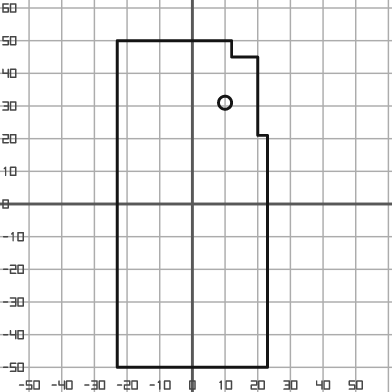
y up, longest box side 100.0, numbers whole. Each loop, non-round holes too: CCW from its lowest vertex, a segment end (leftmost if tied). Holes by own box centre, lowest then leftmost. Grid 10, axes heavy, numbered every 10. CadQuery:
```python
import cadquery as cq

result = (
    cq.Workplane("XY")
    .moveTo(-23.0, -50.0)
    .lineTo(23.0, -50.0)
    .lineTo(23.0, 21.0)
    .lineTo(20.0, 21.0)
    .lineTo(20.0, 45.0)
    .lineTo(12.0, 45.0)
    .lineTo(12.0, 50.0)
    .lineTo(-23.0, 50.0)
    .close()
    .moveTo(10.0, 31.0)
    .circle(2.0)
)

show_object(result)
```